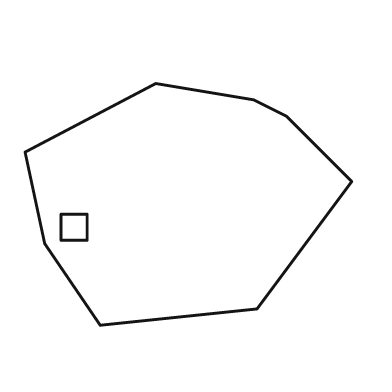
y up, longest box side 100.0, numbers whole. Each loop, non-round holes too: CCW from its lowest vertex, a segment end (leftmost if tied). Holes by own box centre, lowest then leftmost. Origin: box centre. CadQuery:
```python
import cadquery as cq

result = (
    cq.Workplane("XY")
    .moveTo(-27.0, -37.0)
    .lineTo(21.0, -32.0)
    .lineTo(50.0, 7.0)
    .lineTo(30.0, 27.0)
    .lineTo(20.0, 32.0)
    .lineTo(-10.0, 37.0)
    .lineTo(-50.0, 16.0)
    .lineTo(-44.0, -12.0)
    .close()
    .moveTo(-39.0, -11.0)
    .lineTo(-31.0, -11.0)
    .lineTo(-31.0, -3.0)
    .lineTo(-39.0, -3.0)
    .close()
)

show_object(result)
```